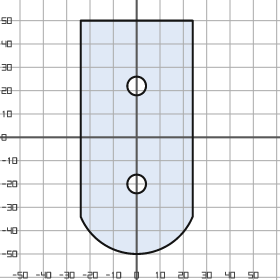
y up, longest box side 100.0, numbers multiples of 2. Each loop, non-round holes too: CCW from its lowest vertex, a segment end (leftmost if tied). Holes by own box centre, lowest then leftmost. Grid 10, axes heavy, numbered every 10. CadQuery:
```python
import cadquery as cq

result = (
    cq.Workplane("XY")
    .moveTo(-24.0, -34.0)
    .threePointArc((0.0, -50.0), (24.0, -34.0))
    .lineTo(24.0, 50.0)
    .lineTo(-24.0, 50.0)
    .close()
    .moveTo(0.0, -20.0)
    .circle(4.0)
    .moveTo(0.0, 22.0)
    .circle(4.0)
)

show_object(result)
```